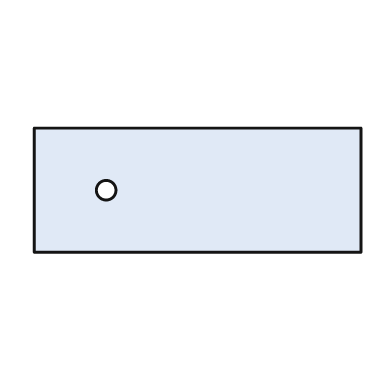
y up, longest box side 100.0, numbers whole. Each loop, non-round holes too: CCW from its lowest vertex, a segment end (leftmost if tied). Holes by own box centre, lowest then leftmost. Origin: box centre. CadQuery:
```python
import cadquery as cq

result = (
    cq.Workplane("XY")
    .moveTo(-50.0, -19.0)
    .lineTo(50.0, -19.0)
    .lineTo(50.0, 19.0)
    .lineTo(-50.0, 19.0)
    .close()
    .moveTo(-28.0, 0.0)
    .circle(3.0)
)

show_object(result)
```